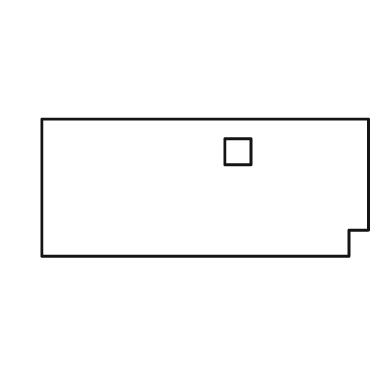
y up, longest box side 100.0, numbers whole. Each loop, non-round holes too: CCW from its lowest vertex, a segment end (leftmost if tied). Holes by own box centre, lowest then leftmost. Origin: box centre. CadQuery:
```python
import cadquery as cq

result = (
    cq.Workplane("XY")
    .moveTo(-50.0, -21.0)
    .lineTo(44.0, -21.0)
    .lineTo(44.0, -13.0)
    .lineTo(50.0, -13.0)
    .lineTo(50.0, 21.0)
    .lineTo(-50.0, 21.0)
    .close()
    .moveTo(6.0, 7.0)
    .lineTo(14.0, 7.0)
    .lineTo(14.0, 15.0)
    .lineTo(6.0, 15.0)
    .close()
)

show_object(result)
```